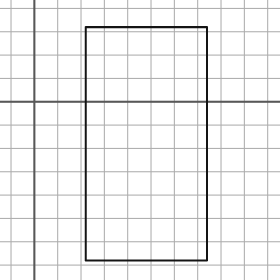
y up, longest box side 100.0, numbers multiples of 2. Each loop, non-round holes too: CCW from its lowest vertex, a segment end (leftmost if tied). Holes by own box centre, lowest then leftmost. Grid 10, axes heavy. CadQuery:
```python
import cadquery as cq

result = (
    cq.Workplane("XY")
    .moveTo(22.0, -68.0)
    .lineTo(74.0, -68.0)
    .lineTo(74.0, 32.0)
    .lineTo(22.0, 32.0)
    .close()
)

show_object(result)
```